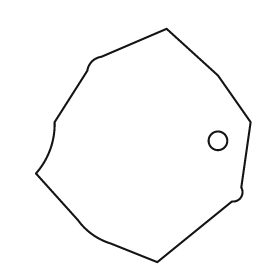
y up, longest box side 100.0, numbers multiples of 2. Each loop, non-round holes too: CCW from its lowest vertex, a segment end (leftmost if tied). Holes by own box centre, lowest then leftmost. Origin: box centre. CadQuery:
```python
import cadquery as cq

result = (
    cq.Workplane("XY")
    .moveTo(6.0, -50.0)
    .lineTo(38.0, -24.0)
    .threePointArc((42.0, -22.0), (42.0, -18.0))
    .lineTo(46.0, 10.0)
    .lineTo(32.0, 30.0)
    .lineTo(10.0, 50.0)
    .lineTo(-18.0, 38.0)
    .threePointArc((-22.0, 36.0), (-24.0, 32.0))
    .lineTo(-38.0, 10.0)
    .threePointArc((-40.0, -2.0), (-46.0, -12.0))
    .lineTo(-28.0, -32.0)
    .threePointArc((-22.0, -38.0), (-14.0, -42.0))
    .close()
    .moveTo(32.0, 2.0)
    .circle(4.0)
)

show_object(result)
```